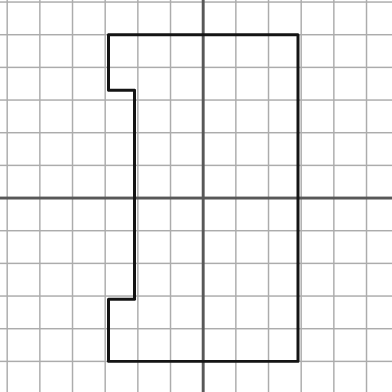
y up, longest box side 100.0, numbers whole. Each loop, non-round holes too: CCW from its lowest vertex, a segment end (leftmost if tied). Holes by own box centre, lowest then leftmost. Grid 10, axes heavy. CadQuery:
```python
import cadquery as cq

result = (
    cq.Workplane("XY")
    .moveTo(-29.0, -50.0)
    .lineTo(29.0, -50.0)
    .lineTo(29.0, 50.0)
    .lineTo(-29.0, 50.0)
    .lineTo(-29.0, 33.0)
    .lineTo(-21.0, 33.0)
    .lineTo(-21.0, -31.0)
    .lineTo(-29.0, -31.0)
    .close()
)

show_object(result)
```